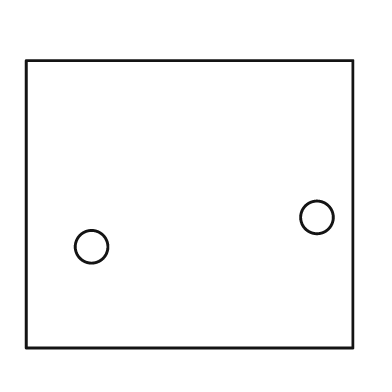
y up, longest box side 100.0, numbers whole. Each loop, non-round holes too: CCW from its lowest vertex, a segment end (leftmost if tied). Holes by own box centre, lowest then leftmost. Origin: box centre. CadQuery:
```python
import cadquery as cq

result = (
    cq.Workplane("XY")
    .moveTo(-50.0, -44.0)
    .lineTo(50.0, -44.0)
    .lineTo(50.0, 44.0)
    .lineTo(-50.0, 44.0)
    .close()
    .moveTo(-30.0, -13.0)
    .circle(5.0)
    .moveTo(39.0, -4.0)
    .circle(5.0)
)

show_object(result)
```